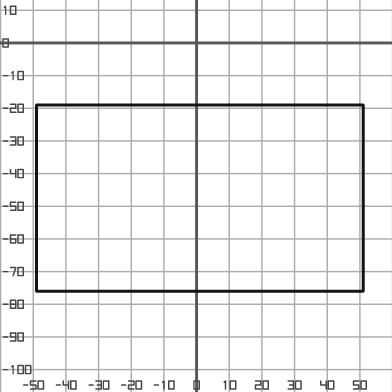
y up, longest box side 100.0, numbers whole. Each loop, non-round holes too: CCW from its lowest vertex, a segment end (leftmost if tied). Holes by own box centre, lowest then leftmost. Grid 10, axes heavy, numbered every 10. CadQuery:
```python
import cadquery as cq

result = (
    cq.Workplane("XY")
    .moveTo(-49.0, -76.0)
    .lineTo(51.0, -76.0)
    .lineTo(51.0, -19.0)
    .lineTo(-49.0, -19.0)
    .close()
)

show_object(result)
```